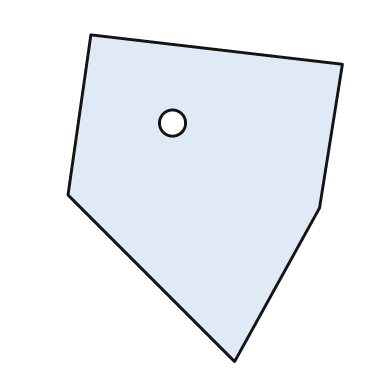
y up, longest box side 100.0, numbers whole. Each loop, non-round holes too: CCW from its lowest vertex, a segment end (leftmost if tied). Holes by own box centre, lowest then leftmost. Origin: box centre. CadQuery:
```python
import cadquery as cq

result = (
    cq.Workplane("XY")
    .moveTo(9.0, -50.0)
    .lineTo(35.0, -3.0)
    .lineTo(42.0, 41.0)
    .lineTo(-35.0, 50.0)
    .lineTo(-42.0, 1.0)
    .close()
    .moveTo(-10.0, 23.0)
    .circle(4.0)
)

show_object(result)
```